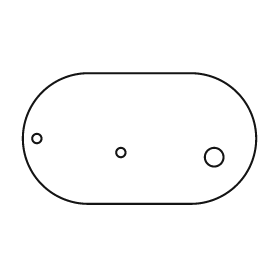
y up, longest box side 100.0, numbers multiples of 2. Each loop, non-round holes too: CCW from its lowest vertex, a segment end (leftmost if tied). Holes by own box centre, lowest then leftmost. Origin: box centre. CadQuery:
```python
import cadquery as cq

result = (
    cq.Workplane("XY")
    .moveTo(-22.0, -28.0)
    .lineTo(22.0, -28.0)
    .threePointArc((50.0, 0.0), (22.0, 28.0))
    .lineTo(-22.0, 28.0)
    .threePointArc((-50.0, 0.0), (-22.0, -28.0))
    .close()
    .moveTo(32.0, -8.0)
    .circle(4.0)
    .moveTo(-8.0, -6.0)
    .circle(2.0)
    .moveTo(-44.0, 0.0)
    .circle(2.0)
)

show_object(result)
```